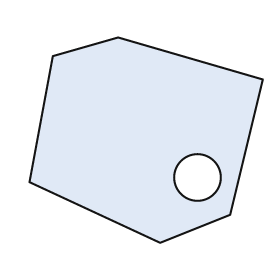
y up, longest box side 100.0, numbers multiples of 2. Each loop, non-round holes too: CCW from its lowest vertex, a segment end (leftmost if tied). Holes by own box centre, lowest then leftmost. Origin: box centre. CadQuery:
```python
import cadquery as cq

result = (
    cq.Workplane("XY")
    .moveTo(6.0, -44.0)
    .lineTo(36.0, -32.0)
    .lineTo(50.0, 26.0)
    .lineTo(-12.0, 44.0)
    .lineTo(-40.0, 36.0)
    .lineTo(-50.0, -18.0)
    .close()
    .moveTo(22.0, -16.0)
    .circle(10.0)
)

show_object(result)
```